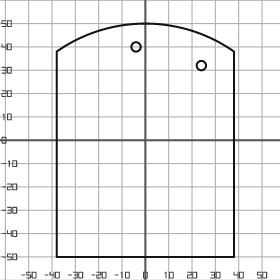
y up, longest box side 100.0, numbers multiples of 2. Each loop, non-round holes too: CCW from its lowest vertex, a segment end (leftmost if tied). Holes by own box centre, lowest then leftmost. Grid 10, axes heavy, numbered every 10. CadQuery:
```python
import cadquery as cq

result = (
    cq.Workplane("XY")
    .moveTo(-38.0, -50.0)
    .lineTo(38.0, -50.0)
    .lineTo(38.0, 38.0)
    .threePointArc((0.0, 50.0), (-38.0, 38.0))
    .close()
    .moveTo(24.0, 32.0)
    .circle(2.0)
    .moveTo(-4.0, 40.0)
    .circle(2.0)
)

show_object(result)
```